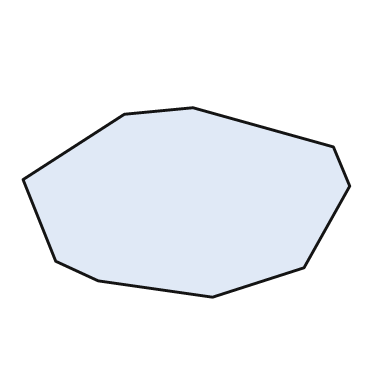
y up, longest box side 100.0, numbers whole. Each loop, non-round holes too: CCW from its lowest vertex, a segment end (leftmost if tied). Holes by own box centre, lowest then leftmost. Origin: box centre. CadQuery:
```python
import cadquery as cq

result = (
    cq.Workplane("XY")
    .moveTo(8.0, -29.0)
    .lineTo(36.0, -20.0)
    .lineTo(50.0, 5.0)
    .lineTo(45.0, 17.0)
    .lineTo(2.0, 29.0)
    .lineTo(-19.0, 27.0)
    .lineTo(-50.0, 7.0)
    .lineTo(-40.0, -18.0)
    .lineTo(-27.0, -24.0)
    .close()
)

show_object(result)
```